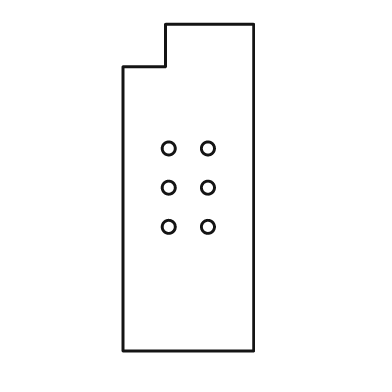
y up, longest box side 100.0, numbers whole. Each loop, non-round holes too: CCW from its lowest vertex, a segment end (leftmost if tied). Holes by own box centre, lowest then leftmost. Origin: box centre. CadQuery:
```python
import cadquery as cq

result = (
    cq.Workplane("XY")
    .moveTo(-20.0, -50.0)
    .lineTo(20.0, -50.0)
    .lineTo(20.0, 50.0)
    .lineTo(-7.0, 50.0)
    .lineTo(-7.0, 37.0)
    .lineTo(-20.0, 37.0)
    .close()
    .moveTo(-6.0, -12.0)
    .circle(2.0)
    .moveTo(6.0, -12.0)
    .circle(2.0)
    .moveTo(-6.0, 0.0)
    .circle(2.0)
    .moveTo(6.0, 0.0)
    .circle(2.0)
    .moveTo(-6.0, 12.0)
    .circle(2.0)
    .moveTo(6.0, 12.0)
    .circle(2.0)
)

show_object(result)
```